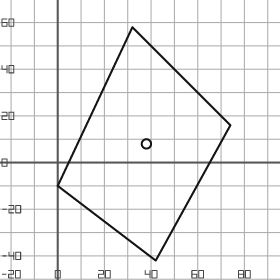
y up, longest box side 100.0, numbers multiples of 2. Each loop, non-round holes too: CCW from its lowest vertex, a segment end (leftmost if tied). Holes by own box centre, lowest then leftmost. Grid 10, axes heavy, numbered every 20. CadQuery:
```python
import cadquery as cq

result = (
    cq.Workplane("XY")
    .moveTo(42.0, -42.0)
    .lineTo(74.0, 16.0)
    .lineTo(32.0, 58.0)
    .lineTo(0.0, -10.0)
    .close()
    .moveTo(38.0, 8.0)
    .circle(2.0)
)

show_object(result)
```